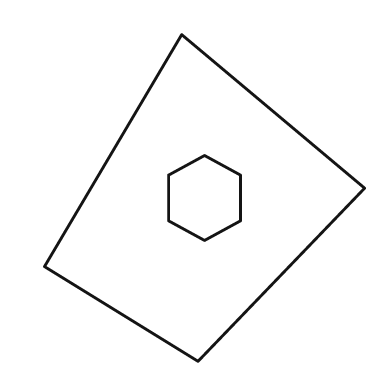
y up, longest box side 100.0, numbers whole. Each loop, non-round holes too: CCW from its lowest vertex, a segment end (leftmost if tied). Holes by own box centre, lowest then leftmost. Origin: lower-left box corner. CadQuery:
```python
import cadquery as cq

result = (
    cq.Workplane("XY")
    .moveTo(47.0, 0.0)
    .lineTo(98.0, 53.0)
    .lineTo(42.0, 100.0)
    .lineTo(0.0, 29.0)
    .close()
    .moveTo(49.0, 37.0)
    .lineTo(60.0, 43.0)
    .lineTo(60.0, 57.0)
    .lineTo(49.0, 63.0)
    .lineTo(38.0, 57.0)
    .lineTo(38.0, 43.0)
    .close()
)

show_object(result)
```